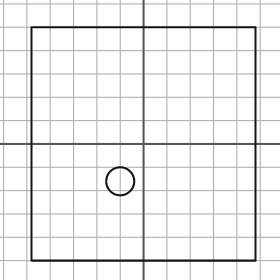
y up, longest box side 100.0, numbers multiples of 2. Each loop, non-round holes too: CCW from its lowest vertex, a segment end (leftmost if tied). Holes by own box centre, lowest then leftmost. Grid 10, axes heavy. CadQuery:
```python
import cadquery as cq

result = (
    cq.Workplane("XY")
    .moveTo(-48.0, -50.0)
    .lineTo(48.0, -50.0)
    .lineTo(48.0, 50.0)
    .lineTo(-48.0, 50.0)
    .close()
    .moveTo(-10.0, -16.0)
    .circle(6.0)
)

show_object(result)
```